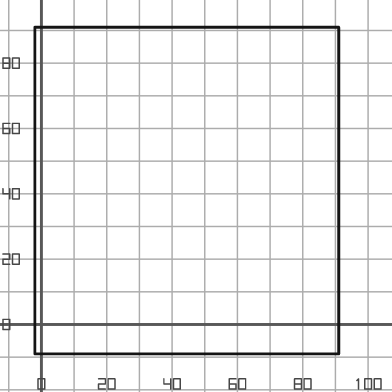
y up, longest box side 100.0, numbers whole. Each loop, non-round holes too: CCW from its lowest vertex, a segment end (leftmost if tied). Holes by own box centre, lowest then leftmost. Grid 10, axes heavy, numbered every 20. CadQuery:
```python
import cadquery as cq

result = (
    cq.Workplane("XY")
    .moveTo(-2.0, -9.0)
    .lineTo(91.0, -9.0)
    .lineTo(91.0, 91.0)
    .lineTo(-2.0, 91.0)
    .close()
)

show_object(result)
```